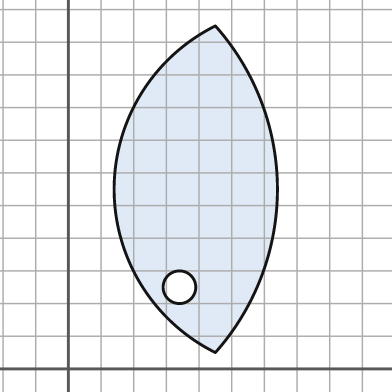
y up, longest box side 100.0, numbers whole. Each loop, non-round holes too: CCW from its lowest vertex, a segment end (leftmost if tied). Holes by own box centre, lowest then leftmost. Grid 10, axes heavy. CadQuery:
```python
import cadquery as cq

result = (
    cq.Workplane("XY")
    .moveTo(45.0, 5.0)
    .threePointArc((64.0, 55.0), (45.0, 105.0))
    .threePointArc((14.0, 55.0), (45.0, 5.0))
    .close()
    .moveTo(34.0, 25.0)
    .circle(5.0)
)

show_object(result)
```